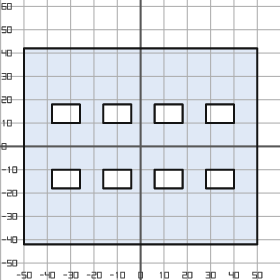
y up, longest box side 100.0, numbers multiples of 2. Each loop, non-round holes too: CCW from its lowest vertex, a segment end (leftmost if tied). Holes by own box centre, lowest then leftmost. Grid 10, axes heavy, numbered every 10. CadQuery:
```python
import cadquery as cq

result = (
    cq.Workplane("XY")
    .moveTo(-50.0, -42.0)
    .lineTo(50.0, -42.0)
    .lineTo(50.0, 42.0)
    .lineTo(-50.0, 42.0)
    .close()
    .moveTo(-38.0, -18.0)
    .lineTo(-26.0, -18.0)
    .lineTo(-26.0, -10.0)
    .lineTo(-38.0, -10.0)
    .close()
    .moveTo(-16.0, -18.0)
    .lineTo(-4.0, -18.0)
    .lineTo(-4.0, -10.0)
    .lineTo(-16.0, -10.0)
    .close()
    .moveTo(6.0, -18.0)
    .lineTo(18.0, -18.0)
    .lineTo(18.0, -10.0)
    .lineTo(6.0, -10.0)
    .close()
    .moveTo(28.0, -18.0)
    .lineTo(40.0, -18.0)
    .lineTo(40.0, -10.0)
    .lineTo(28.0, -10.0)
    .close()
    .moveTo(-38.0, 10.0)
    .lineTo(-26.0, 10.0)
    .lineTo(-26.0, 18.0)
    .lineTo(-38.0, 18.0)
    .close()
    .moveTo(-16.0, 10.0)
    .lineTo(-4.0, 10.0)
    .lineTo(-4.0, 18.0)
    .lineTo(-16.0, 18.0)
    .close()
    .moveTo(6.0, 10.0)
    .lineTo(18.0, 10.0)
    .lineTo(18.0, 18.0)
    .lineTo(6.0, 18.0)
    .close()
    .moveTo(28.0, 10.0)
    .lineTo(40.0, 10.0)
    .lineTo(40.0, 18.0)
    .lineTo(28.0, 18.0)
    .close()
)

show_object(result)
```